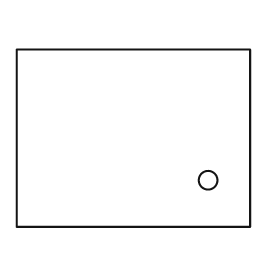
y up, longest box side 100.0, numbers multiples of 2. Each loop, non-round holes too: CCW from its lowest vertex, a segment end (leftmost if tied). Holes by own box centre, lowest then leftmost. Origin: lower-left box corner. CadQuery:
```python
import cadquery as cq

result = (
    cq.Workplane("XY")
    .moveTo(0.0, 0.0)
    .lineTo(100.0, 0.0)
    .lineTo(100.0, 76.0)
    .lineTo(0.0, 76.0)
    .close()
    .moveTo(82.0, 20.0)
    .circle(4.0)
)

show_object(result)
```